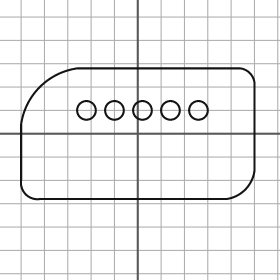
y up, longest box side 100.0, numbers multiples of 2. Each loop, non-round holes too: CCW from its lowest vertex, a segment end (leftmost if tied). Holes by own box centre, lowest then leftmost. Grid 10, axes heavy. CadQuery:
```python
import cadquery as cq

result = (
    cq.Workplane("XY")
    .moveTo(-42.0, -28.0)
    .lineTo(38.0, -28.0)
    .threePointArc((46.0, -24.0), (50.0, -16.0))
    .lineTo(50.0, 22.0)
    .threePointArc((48.0, 26.0), (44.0, 28.0))
    .lineTo(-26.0, 28.0)
    .threePointArc((-42.0, 20.0), (-50.0, 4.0))
    .lineTo(-50.0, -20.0)
    .threePointArc((-48.0, -26.0), (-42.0, -28.0))
    .close()
    .moveTo(-22.0, 10.0)
    .circle(4.0)
    .moveTo(-10.0, 10.0)
    .circle(4.0)
    .moveTo(2.0, 10.0)
    .circle(4.0)
    .moveTo(14.0, 10.0)
    .circle(4.0)
    .moveTo(26.0, 10.0)
    .circle(4.0)
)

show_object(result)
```